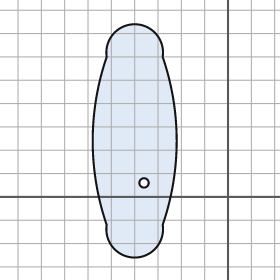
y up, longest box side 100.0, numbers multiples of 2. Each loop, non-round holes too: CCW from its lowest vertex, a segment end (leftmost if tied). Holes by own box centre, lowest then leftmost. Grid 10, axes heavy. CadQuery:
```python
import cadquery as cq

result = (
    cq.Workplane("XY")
    .moveTo(-52.0, -12.0)
    .threePointArc((-40.0, -26.0), (-28.0, -12.0))
    .threePointArc((-22.0, 24.0), (-28.0, 60.0))
    .threePointArc((-40.0, 74.0), (-52.0, 60.0))
    .threePointArc((-58.0, 24.0), (-52.0, -12.0))
    .close()
    .moveTo(-36.0, 6.0)
    .circle(2.0)
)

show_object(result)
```